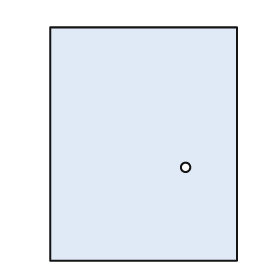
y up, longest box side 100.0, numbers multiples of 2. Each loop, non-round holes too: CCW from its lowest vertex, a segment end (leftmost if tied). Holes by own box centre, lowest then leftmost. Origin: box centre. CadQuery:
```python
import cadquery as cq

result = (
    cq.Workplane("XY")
    .moveTo(-40.0, -50.0)
    .lineTo(40.0, -50.0)
    .lineTo(40.0, 50.0)
    .lineTo(-40.0, 50.0)
    .close()
    .moveTo(18.0, -10.0)
    .circle(2.0)
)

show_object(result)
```